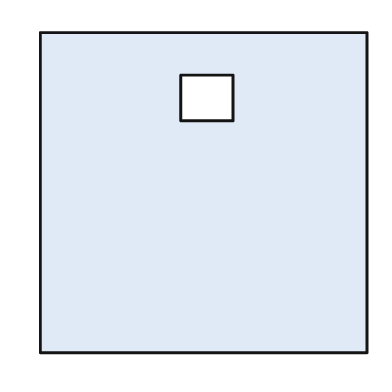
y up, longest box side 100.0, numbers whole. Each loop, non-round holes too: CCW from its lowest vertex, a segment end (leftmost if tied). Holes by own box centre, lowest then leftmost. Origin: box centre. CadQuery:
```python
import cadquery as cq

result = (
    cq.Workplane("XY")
    .moveTo(-50.0, -49.0)
    .lineTo(50.0, -49.0)
    .lineTo(50.0, 49.0)
    .lineTo(-50.0, 49.0)
    .close()
    .moveTo(-7.0, 22.0)
    .lineTo(9.0, 22.0)
    .lineTo(9.0, 36.0)
    .lineTo(-7.0, 36.0)
    .close()
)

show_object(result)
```